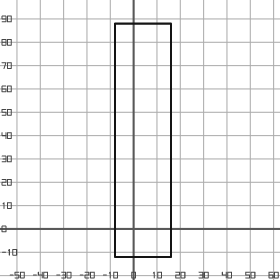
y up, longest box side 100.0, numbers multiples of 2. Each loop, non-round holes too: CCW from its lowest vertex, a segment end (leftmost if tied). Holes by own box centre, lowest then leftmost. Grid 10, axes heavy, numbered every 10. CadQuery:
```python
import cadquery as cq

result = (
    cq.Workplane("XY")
    .moveTo(-8.0, -12.0)
    .lineTo(16.0, -12.0)
    .lineTo(16.0, 88.0)
    .lineTo(-8.0, 88.0)
    .close()
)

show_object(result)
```